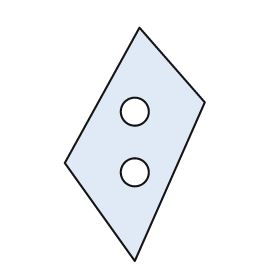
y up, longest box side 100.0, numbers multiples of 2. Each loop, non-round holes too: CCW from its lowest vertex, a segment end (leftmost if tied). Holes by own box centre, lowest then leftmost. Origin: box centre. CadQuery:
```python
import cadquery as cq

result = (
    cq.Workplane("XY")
    .moveTo(0.0, -50.0)
    .lineTo(30.0, 18.0)
    .lineTo(2.0, 50.0)
    .lineTo(-30.0, -8.0)
    .close()
    .moveTo(0.0, -12.0)
    .circle(6.0)
    .moveTo(0.0, 14.0)
    .circle(6.0)
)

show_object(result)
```